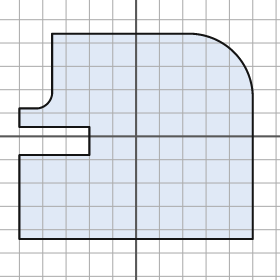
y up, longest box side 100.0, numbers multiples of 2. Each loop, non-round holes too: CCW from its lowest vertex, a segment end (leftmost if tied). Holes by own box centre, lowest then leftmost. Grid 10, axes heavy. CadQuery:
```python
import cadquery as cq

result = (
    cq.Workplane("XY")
    .moveTo(-50.0, -44.0)
    .lineTo(50.0, -44.0)
    .lineTo(50.0, 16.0)
    .threePointArc((42.0, 36.0), (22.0, 44.0))
    .lineTo(-36.0, 44.0)
    .lineTo(-36.0, 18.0)
    .threePointArc((-38.0, 14.0), (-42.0, 12.0))
    .lineTo(-50.0, 12.0)
    .lineTo(-50.0, 4.0)
    .lineTo(-20.0, 4.0)
    .lineTo(-20.0, -8.0)
    .lineTo(-50.0, -8.0)
    .close()
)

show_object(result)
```